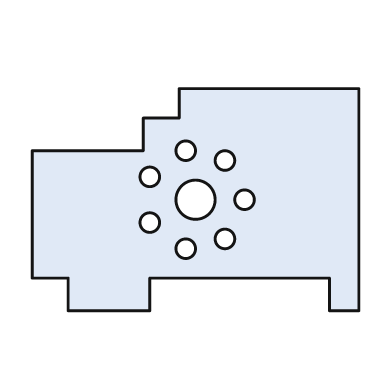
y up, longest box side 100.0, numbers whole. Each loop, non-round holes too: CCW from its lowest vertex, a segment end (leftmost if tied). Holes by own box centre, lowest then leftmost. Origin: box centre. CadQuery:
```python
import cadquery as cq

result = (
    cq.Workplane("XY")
    .moveTo(-39.0, -34.0)
    .lineTo(-14.0, -34.0)
    .lineTo(-14.0, -24.0)
    .lineTo(41.0, -24.0)
    .lineTo(41.0, -34.0)
    .lineTo(50.0, -34.0)
    .lineTo(50.0, 34.0)
    .lineTo(-5.0, 34.0)
    .lineTo(-5.0, 25.0)
    .lineTo(-16.0, 25.0)
    .lineTo(-16.0, 15.0)
    .lineTo(-50.0, 15.0)
    .lineTo(-50.0, -24.0)
    .lineTo(-39.0, -24.0)
    .close()
    .moveTo(-3.0, -15.0)
    .circle(3.0)
    .moveTo(9.0, -12.0)
    .circle(3.0)
    .moveTo(-14.0, -7.0)
    .circle(3.0)
    .moveTo(0.0, 0.0)
    .circle(6.0)
    .moveTo(15.0, 0.0)
    .circle(3.0)
    .moveTo(-14.0, 7.0)
    .circle(3.0)
    .moveTo(9.0, 12.0)
    .circle(3.0)
    .moveTo(-3.0, 15.0)
    .circle(3.0)
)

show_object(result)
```